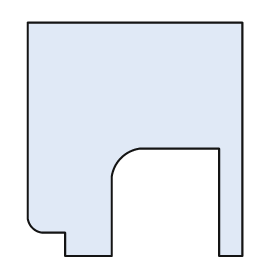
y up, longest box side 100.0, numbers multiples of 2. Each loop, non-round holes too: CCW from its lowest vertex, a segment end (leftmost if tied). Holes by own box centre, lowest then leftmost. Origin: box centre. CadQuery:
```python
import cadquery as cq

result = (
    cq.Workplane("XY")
    .moveTo(-30.0, -50.0)
    .lineTo(-10.0, -50.0)
    .lineTo(-10.0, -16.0)
    .threePointArc((-6.0, -8.0), (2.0, -4.0))
    .lineTo(36.0, -4.0)
    .lineTo(36.0, -50.0)
    .lineTo(46.0, -50.0)
    .lineTo(46.0, 50.0)
    .lineTo(-46.0, 50.0)
    .lineTo(-46.0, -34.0)
    .threePointArc((-44.0, -38.0), (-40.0, -40.0))
    .lineTo(-30.0, -40.0)
    .close()
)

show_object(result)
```